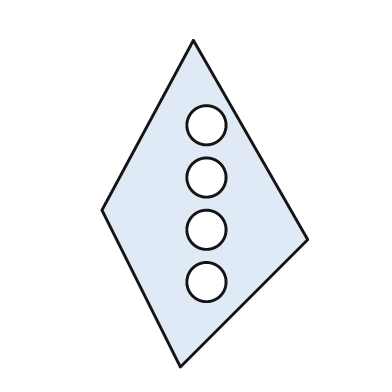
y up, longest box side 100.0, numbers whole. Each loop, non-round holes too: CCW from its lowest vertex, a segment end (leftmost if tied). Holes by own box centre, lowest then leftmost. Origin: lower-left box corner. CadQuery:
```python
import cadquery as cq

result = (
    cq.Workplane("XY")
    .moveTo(24.0, 0.0)
    .lineTo(63.0, 39.0)
    .lineTo(28.0, 100.0)
    .lineTo(0.0, 48.0)
    .close()
    .moveTo(32.0, 26.0)
    .circle(6.0)
    .moveTo(32.0, 42.0)
    .circle(6.0)
    .moveTo(32.0, 58.0)
    .circle(6.0)
    .moveTo(32.0, 74.0)
    .circle(6.0)
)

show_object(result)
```